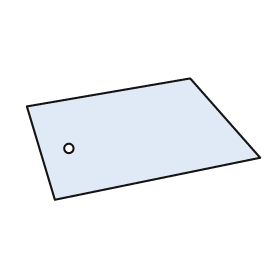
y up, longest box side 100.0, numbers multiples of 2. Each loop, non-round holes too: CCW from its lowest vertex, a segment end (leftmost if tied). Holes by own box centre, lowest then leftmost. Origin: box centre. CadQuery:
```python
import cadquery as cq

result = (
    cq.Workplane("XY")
    .moveTo(-38.0, -26.0)
    .lineTo(50.0, -8.0)
    .lineTo(20.0, 26.0)
    .lineTo(-50.0, 14.0)
    .close()
    .moveTo(-32.0, -4.0)
    .circle(2.0)
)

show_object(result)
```